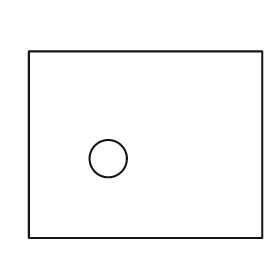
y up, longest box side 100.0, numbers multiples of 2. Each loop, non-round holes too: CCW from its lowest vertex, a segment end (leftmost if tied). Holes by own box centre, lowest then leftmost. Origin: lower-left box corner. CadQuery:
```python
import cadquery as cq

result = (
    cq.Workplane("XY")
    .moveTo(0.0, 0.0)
    .lineTo(100.0, 0.0)
    .lineTo(100.0, 80.0)
    .lineTo(0.0, 80.0)
    .close()
    .moveTo(34.0, 34.0)
    .circle(8.0)
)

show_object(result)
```